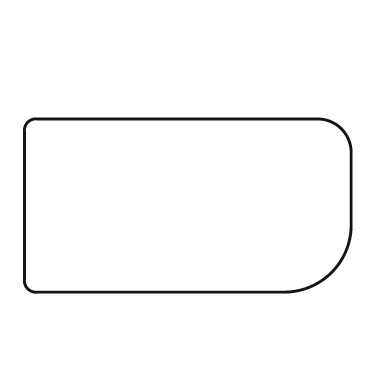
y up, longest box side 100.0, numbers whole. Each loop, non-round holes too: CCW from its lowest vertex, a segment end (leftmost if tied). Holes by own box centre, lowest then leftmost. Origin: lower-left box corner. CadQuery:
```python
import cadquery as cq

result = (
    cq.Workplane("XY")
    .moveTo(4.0, 0.0)
    .lineTo(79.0, 0.0)
    .threePointArc((94.0, 6.0), (100.0, 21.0))
    .lineTo(100.0, 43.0)
    .threePointArc((97.0, 50.0), (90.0, 53.0))
    .lineTo(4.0, 53.0)
    .threePointArc((1.0, 52.0), (0.0, 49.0))
    .lineTo(0.0, 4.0)
    .threePointArc((1.0, 1.0), (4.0, 0.0))
    .close()
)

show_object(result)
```